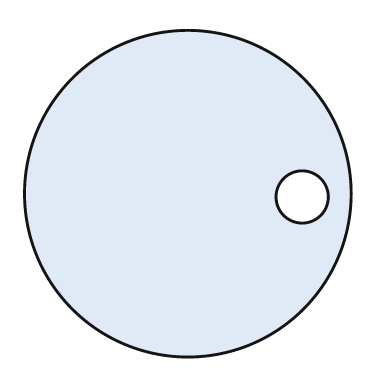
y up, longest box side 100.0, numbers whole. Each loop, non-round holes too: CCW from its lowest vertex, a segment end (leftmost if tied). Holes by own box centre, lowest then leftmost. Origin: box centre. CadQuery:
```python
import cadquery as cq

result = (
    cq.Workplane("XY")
    .moveTo(0.0, 0.0)
    .circle(50.0)
    .moveTo(35.0, -1.0)
    .circle(8.0)
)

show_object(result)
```